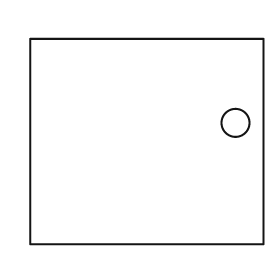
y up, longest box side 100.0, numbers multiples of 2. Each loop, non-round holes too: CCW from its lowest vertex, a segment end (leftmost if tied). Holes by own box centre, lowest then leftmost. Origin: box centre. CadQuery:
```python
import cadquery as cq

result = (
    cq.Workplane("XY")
    .moveTo(-50.0, -44.0)
    .lineTo(50.0, -44.0)
    .lineTo(50.0, 44.0)
    .lineTo(-50.0, 44.0)
    .close()
    .moveTo(38.0, 8.0)
    .circle(6.0)
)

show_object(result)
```